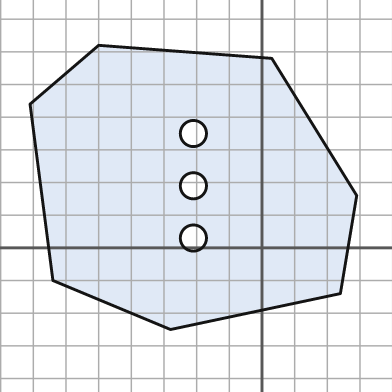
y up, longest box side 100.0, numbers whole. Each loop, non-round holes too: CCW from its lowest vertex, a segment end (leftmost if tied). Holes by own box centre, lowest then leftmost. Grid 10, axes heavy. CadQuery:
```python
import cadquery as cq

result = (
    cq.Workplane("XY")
    .moveTo(-28.0, -25.0)
    .lineTo(24.0, -14.0)
    .lineTo(29.0, 16.0)
    .lineTo(3.0, 58.0)
    .lineTo(-50.0, 62.0)
    .lineTo(-71.0, 44.0)
    .lineTo(-64.0, -10.0)
    .close()
    .moveTo(-21.0, 3.0)
    .circle(4.0)
    .moveTo(-21.0, 19.0)
    .circle(4.0)
    .moveTo(-21.0, 35.0)
    .circle(4.0)
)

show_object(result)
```